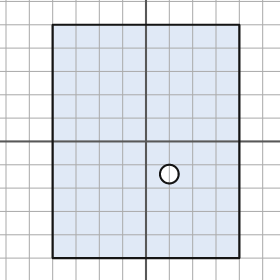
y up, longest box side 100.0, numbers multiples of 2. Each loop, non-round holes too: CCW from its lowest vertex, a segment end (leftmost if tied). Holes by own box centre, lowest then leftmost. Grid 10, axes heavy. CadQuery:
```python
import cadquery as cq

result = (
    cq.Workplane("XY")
    .moveTo(-40.0, -50.0)
    .lineTo(40.0, -50.0)
    .lineTo(40.0, 50.0)
    .lineTo(-40.0, 50.0)
    .close()
    .moveTo(10.0, -14.0)
    .circle(4.0)
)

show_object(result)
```